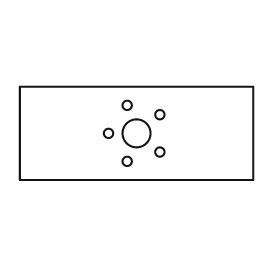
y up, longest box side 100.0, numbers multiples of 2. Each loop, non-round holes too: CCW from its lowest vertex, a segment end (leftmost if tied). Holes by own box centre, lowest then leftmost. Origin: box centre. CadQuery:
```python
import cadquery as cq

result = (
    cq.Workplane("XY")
    .moveTo(-50.0, -20.0)
    .lineTo(50.0, -20.0)
    .lineTo(50.0, 20.0)
    .lineTo(-50.0, 20.0)
    .close()
    .moveTo(-4.0, -12.0)
    .circle(2.0)
    .moveTo(10.0, -8.0)
    .circle(2.0)
    .moveTo(-12.0, 0.0)
    .circle(2.0)
    .moveTo(0.0, 0.0)
    .circle(6.0)
    .moveTo(10.0, 8.0)
    .circle(2.0)
    .moveTo(-4.0, 12.0)
    .circle(2.0)
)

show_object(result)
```